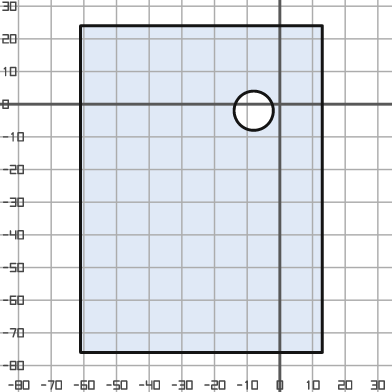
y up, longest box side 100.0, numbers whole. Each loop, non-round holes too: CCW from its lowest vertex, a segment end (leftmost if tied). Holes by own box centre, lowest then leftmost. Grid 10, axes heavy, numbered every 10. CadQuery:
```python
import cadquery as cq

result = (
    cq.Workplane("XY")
    .moveTo(-61.0, -76.0)
    .lineTo(13.0, -76.0)
    .lineTo(13.0, 24.0)
    .lineTo(-61.0, 24.0)
    .close()
    .moveTo(-8.0, -2.0)
    .circle(6.0)
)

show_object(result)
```